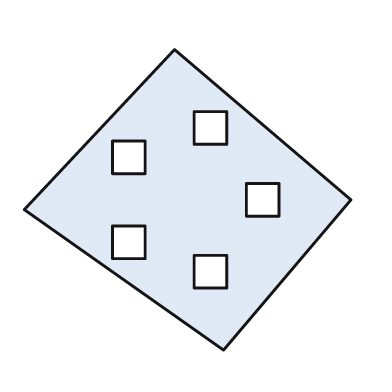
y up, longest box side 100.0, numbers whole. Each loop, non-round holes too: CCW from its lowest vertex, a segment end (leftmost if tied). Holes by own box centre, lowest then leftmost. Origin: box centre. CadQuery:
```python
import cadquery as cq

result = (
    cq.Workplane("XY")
    .moveTo(11.0, -46.0)
    .lineTo(50.0, 0.0)
    .lineTo(-4.0, 46.0)
    .lineTo(-50.0, -3.0)
    .close()
    .moveTo(2.0, -27.0)
    .lineTo(12.0, -27.0)
    .lineTo(12.0, -17.0)
    .lineTo(2.0, -17.0)
    .close()
    .moveTo(-23.0, -18.0)
    .lineTo(-13.0, -18.0)
    .lineTo(-13.0, -8.0)
    .lineTo(-23.0, -8.0)
    .close()
    .moveTo(18.0, -5.0)
    .lineTo(28.0, -5.0)
    .lineTo(28.0, 5.0)
    .lineTo(18.0, 5.0)
    .close()
    .moveTo(-23.0, 8.0)
    .lineTo(-13.0, 8.0)
    .lineTo(-13.0, 18.0)
    .lineTo(-23.0, 18.0)
    .close()
    .moveTo(2.0, 17.0)
    .lineTo(12.0, 17.0)
    .lineTo(12.0, 27.0)
    .lineTo(2.0, 27.0)
    .close()
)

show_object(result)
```